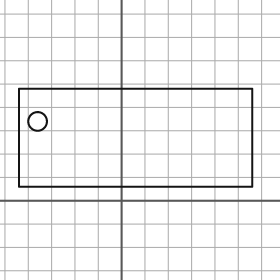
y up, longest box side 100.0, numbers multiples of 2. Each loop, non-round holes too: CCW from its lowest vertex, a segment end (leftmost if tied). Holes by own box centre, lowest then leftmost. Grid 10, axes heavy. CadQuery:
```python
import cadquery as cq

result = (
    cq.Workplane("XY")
    .moveTo(-44.0, 6.0)
    .lineTo(56.0, 6.0)
    .lineTo(56.0, 48.0)
    .lineTo(-44.0, 48.0)
    .close()
    .moveTo(-36.0, 34.0)
    .circle(4.0)
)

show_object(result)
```